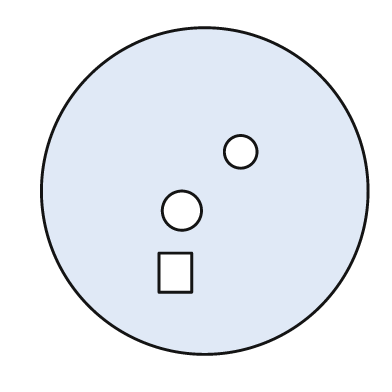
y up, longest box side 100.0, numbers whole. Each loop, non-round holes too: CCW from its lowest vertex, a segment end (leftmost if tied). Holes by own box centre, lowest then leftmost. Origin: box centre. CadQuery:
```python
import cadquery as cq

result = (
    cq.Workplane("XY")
    .moveTo(0.0, 0.0)
    .circle(50.0)
    .moveTo(-14.0, -31.0)
    .lineTo(-4.0, -31.0)
    .lineTo(-4.0, -19.0)
    .lineTo(-14.0, -19.0)
    .close()
    .moveTo(-7.0, -6.0)
    .circle(6.0)
    .moveTo(11.0, 12.0)
    .circle(5.0)
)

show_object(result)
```